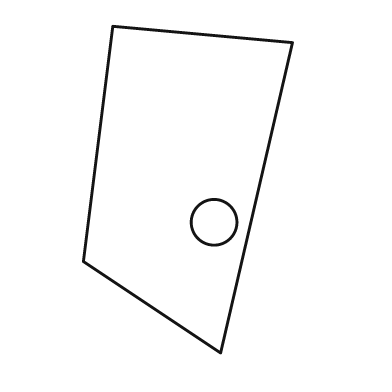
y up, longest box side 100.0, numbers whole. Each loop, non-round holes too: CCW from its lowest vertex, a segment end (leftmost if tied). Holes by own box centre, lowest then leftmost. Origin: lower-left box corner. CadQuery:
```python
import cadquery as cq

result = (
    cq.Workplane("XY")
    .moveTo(42.0, 0.0)
    .lineTo(64.0, 95.0)
    .lineTo(9.0, 100.0)
    .lineTo(0.0, 28.0)
    .close()
    .moveTo(40.0, 40.0)
    .circle(7.0)
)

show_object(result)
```